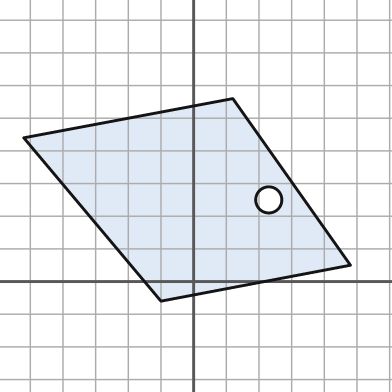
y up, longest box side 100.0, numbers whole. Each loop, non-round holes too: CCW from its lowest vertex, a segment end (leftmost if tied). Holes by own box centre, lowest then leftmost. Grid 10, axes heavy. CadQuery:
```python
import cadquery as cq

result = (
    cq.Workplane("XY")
    .moveTo(-10.0, -6.0)
    .lineTo(48.0, 5.0)
    .lineTo(12.0, 56.0)
    .lineTo(-52.0, 44.0)
    .close()
    .moveTo(23.0, 25.0)
    .circle(4.0)
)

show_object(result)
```